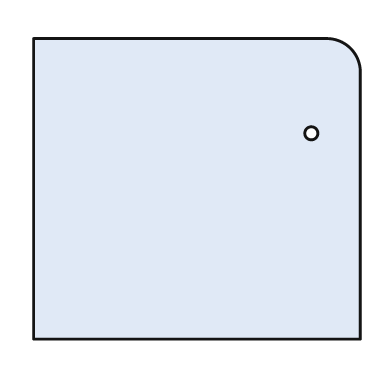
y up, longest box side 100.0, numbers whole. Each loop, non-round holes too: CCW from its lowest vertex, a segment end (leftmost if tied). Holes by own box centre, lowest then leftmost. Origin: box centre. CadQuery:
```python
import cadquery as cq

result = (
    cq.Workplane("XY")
    .moveTo(-50.0, -46.0)
    .lineTo(50.0, -46.0)
    .lineTo(50.0, 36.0)
    .threePointArc((47.0, 43.0), (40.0, 46.0))
    .lineTo(-50.0, 46.0)
    .close()
    .moveTo(35.0, 17.0)
    .circle(2.0)
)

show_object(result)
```